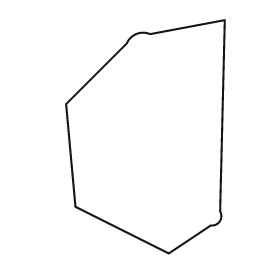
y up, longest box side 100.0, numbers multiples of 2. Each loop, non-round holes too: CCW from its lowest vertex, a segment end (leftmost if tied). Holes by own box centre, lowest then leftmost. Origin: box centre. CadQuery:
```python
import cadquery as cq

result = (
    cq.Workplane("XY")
    .moveTo(10.0, -50.0)
    .lineTo(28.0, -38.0)
    .threePointArc((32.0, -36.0), (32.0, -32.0))
    .lineTo(34.0, 50.0)
    .lineTo(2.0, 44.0)
    .threePointArc((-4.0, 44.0), (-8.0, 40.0))
    .lineTo(-34.0, 14.0)
    .lineTo(-30.0, -30.0)
    .close()
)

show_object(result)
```